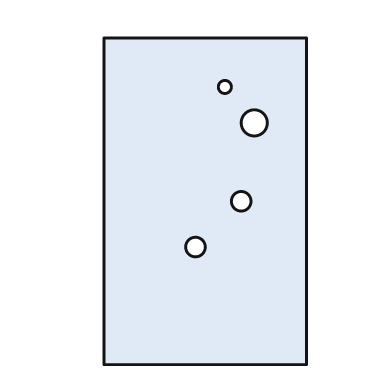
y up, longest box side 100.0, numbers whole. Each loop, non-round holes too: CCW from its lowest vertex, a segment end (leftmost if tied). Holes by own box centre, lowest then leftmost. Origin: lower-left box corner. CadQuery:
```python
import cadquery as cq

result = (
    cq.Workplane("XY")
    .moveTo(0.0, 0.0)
    .lineTo(62.0, 0.0)
    .lineTo(62.0, 100.0)
    .lineTo(0.0, 100.0)
    .close()
    .moveTo(28.0, 36.0)
    .circle(3.0)
    .moveTo(42.0, 50.0)
    .circle(3.0)
    .moveTo(46.0, 74.0)
    .circle(4.0)
    .moveTo(37.0, 85.0)
    .circle(2.0)
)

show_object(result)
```